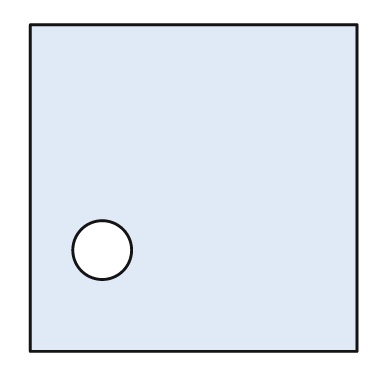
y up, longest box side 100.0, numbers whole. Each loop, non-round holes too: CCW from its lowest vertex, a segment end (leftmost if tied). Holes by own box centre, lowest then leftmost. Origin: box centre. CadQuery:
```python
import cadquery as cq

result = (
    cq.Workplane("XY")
    .moveTo(-50.0, -50.0)
    .lineTo(50.0, -50.0)
    .lineTo(50.0, 50.0)
    .lineTo(-50.0, 50.0)
    .close()
    .moveTo(-28.0, -19.0)
    .circle(9.0)
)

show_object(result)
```